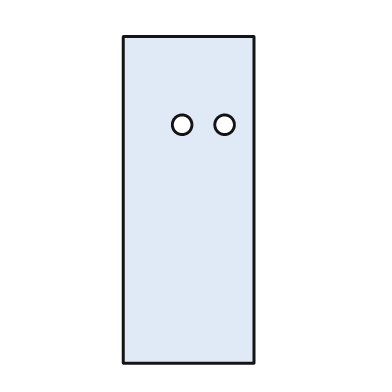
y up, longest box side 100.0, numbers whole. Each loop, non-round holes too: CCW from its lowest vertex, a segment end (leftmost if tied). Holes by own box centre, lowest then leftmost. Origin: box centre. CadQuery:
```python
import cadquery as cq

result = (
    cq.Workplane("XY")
    .moveTo(-20.0, -50.0)
    .lineTo(20.0, -50.0)
    .lineTo(20.0, 50.0)
    .lineTo(-20.0, 50.0)
    .close()
    .moveTo(-2.0, 23.0)
    .circle(3.0)
    .moveTo(11.0, 23.0)
    .circle(3.0)
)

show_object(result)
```